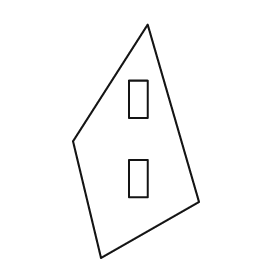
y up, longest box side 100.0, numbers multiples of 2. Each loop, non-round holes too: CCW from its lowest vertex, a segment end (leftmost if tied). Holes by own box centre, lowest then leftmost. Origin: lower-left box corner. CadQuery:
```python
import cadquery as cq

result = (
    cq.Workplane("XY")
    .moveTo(12.0, 0.0)
    .lineTo(54.0, 24.0)
    .lineTo(32.0, 100.0)
    .lineTo(0.0, 50.0)
    .close()
    .moveTo(24.0, 26.0)
    .lineTo(32.0, 26.0)
    .lineTo(32.0, 42.0)
    .lineTo(24.0, 42.0)
    .close()
    .moveTo(24.0, 60.0)
    .lineTo(32.0, 60.0)
    .lineTo(32.0, 76.0)
    .lineTo(24.0, 76.0)
    .close()
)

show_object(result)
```